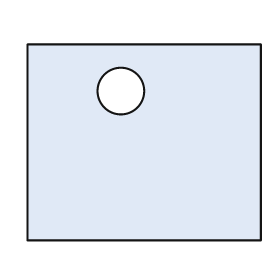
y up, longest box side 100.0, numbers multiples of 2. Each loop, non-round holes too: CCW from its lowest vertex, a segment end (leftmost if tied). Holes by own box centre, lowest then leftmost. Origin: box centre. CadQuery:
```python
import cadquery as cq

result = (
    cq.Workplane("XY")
    .moveTo(-50.0, -42.0)
    .lineTo(50.0, -42.0)
    .lineTo(50.0, 42.0)
    .lineTo(-50.0, 42.0)
    .close()
    .moveTo(-10.0, 22.0)
    .circle(10.0)
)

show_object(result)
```